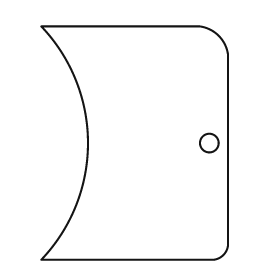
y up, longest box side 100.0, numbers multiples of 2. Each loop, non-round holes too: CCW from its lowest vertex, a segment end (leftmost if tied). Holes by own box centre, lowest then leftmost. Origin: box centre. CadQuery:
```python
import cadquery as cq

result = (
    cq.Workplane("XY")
    .moveTo(-40.0, -50.0)
    .lineTo(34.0, -50.0)
    .threePointArc((38.0, -48.0), (40.0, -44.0))
    .lineTo(40.0, 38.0)
    .threePointArc((36.0, 46.0), (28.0, 50.0))
    .lineTo(-40.0, 50.0)
    .threePointArc((-20.0, 0.0), (-40.0, -50.0))
    .close()
    .moveTo(32.0, 0.0)
    .circle(4.0)
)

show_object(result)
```